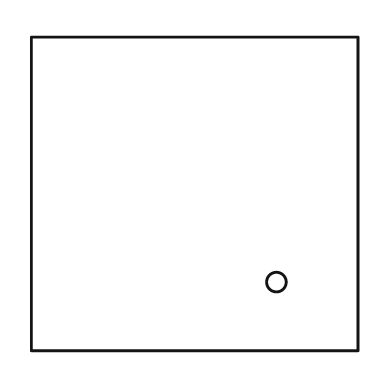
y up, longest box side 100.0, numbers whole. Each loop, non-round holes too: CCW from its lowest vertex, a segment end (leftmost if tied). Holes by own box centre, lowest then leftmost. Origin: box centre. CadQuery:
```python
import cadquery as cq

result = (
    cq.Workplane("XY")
    .moveTo(-50.0, -48.0)
    .lineTo(50.0, -48.0)
    .lineTo(50.0, 48.0)
    .lineTo(-50.0, 48.0)
    .close()
    .moveTo(25.0, -27.0)
    .circle(3.0)
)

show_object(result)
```